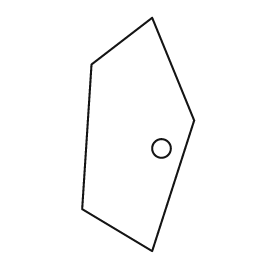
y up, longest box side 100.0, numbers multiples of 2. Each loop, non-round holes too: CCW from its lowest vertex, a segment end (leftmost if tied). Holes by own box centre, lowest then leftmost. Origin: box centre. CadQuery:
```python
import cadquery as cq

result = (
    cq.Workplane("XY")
    .moveTo(6.0, -50.0)
    .lineTo(24.0, 6.0)
    .lineTo(6.0, 50.0)
    .lineTo(-20.0, 30.0)
    .lineTo(-24.0, -32.0)
    .close()
    .moveTo(10.0, -6.0)
    .circle(4.0)
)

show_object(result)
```